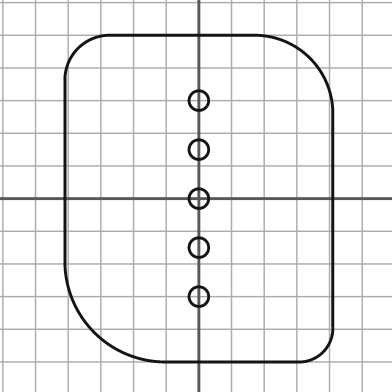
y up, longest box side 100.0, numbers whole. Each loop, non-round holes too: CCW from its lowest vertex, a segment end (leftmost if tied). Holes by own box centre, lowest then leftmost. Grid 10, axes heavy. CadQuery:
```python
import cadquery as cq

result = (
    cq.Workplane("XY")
    .moveTo(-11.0, -50.0)
    .lineTo(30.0, -50.0)
    .threePointArc((38.0, -47.0), (41.0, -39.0))
    .lineTo(41.0, 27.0)
    .threePointArc((34.0, 43.0), (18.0, 50.0))
    .lineTo(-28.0, 50.0)
    .threePointArc((-37.0, 46.0), (-41.0, 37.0))
    .lineTo(-41.0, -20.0)
    .threePointArc((-32.0, -41.0), (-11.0, -50.0))
    .close()
    .moveTo(0.0, -30.0)
    .circle(3.0)
    .moveTo(0.0, -15.0)
    .circle(3.0)
    .moveTo(0.0, 0.0)
    .circle(3.0)
    .moveTo(0.0, 15.0)
    .circle(3.0)
    .moveTo(0.0, 30.0)
    .circle(3.0)
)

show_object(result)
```